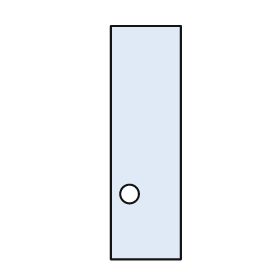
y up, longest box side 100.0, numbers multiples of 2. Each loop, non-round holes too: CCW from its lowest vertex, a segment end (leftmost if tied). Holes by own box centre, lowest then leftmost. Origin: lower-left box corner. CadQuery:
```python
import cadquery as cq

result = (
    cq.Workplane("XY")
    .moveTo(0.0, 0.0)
    .lineTo(30.0, 0.0)
    .lineTo(30.0, 100.0)
    .lineTo(0.0, 100.0)
    .close()
    .moveTo(8.0, 28.0)
    .circle(4.0)
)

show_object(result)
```